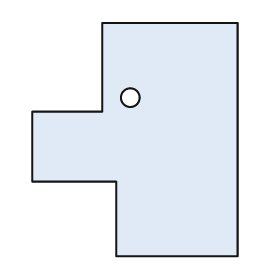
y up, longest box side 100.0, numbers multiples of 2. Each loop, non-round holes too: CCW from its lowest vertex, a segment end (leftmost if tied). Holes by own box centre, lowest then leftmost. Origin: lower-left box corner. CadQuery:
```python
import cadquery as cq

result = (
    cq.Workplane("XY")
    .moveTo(36.0, 0.0)
    .lineTo(88.0, 0.0)
    .lineTo(88.0, 100.0)
    .lineTo(30.0, 100.0)
    .lineTo(30.0, 62.0)
    .lineTo(0.0, 62.0)
    .lineTo(0.0, 32.0)
    .lineTo(36.0, 32.0)
    .close()
    .moveTo(42.0, 68.0)
    .circle(4.0)
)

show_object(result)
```